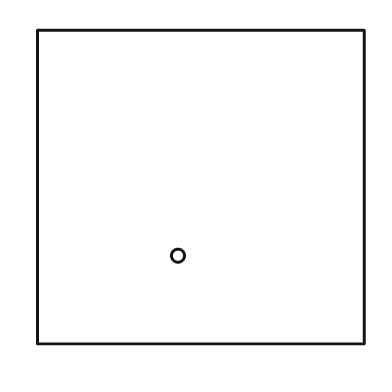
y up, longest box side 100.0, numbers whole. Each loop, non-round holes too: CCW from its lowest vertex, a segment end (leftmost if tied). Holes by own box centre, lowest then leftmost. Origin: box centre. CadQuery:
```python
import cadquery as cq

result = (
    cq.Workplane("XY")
    .moveTo(-50.0, -48.0)
    .lineTo(50.0, -48.0)
    .lineTo(50.0, 48.0)
    .lineTo(-50.0, 48.0)
    .close()
    .moveTo(-7.0, -21.0)
    .circle(2.0)
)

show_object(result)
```